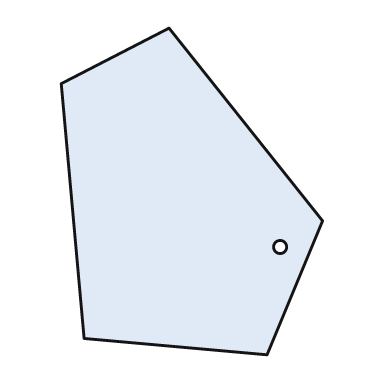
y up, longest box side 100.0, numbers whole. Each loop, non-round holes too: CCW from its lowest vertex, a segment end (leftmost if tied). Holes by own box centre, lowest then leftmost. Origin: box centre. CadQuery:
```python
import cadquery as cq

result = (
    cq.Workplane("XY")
    .moveTo(23.0, -50.0)
    .lineTo(40.0, -9.0)
    .lineTo(-7.0, 50.0)
    .lineTo(-40.0, 33.0)
    .lineTo(-33.0, -45.0)
    .close()
    .moveTo(27.0, -17.0)
    .circle(2.0)
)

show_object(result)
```